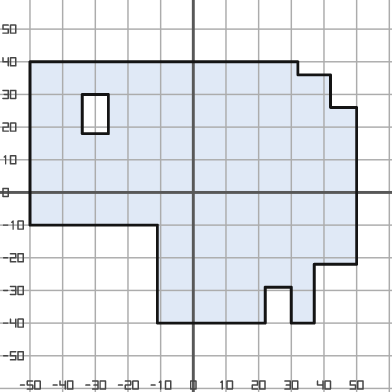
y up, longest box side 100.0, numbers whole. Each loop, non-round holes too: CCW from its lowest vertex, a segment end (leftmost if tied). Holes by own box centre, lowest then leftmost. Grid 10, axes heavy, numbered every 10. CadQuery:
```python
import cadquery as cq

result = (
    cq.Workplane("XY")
    .moveTo(-11.0, -40.0)
    .lineTo(22.0, -40.0)
    .lineTo(22.0, -29.0)
    .lineTo(30.0, -29.0)
    .lineTo(30.0, -40.0)
    .lineTo(37.0, -40.0)
    .lineTo(37.0, -22.0)
    .lineTo(50.0, -22.0)
    .lineTo(50.0, 26.0)
    .lineTo(42.0, 26.0)
    .lineTo(42.0, 36.0)
    .lineTo(32.0, 36.0)
    .lineTo(32.0, 40.0)
    .lineTo(-50.0, 40.0)
    .lineTo(-50.0, -10.0)
    .lineTo(-11.0, -10.0)
    .close()
    .moveTo(-34.0, 18.0)
    .lineTo(-26.0, 18.0)
    .lineTo(-26.0, 30.0)
    .lineTo(-34.0, 30.0)
    .close()
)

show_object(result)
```